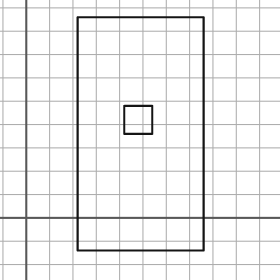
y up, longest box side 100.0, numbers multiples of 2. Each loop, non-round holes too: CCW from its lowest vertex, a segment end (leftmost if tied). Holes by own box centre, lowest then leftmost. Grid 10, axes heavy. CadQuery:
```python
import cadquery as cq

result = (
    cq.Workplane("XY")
    .moveTo(22.0, -14.0)
    .lineTo(76.0, -14.0)
    .lineTo(76.0, 86.0)
    .lineTo(22.0, 86.0)
    .close()
    .moveTo(42.0, 36.0)
    .lineTo(54.0, 36.0)
    .lineTo(54.0, 48.0)
    .lineTo(42.0, 48.0)
    .close()
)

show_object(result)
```